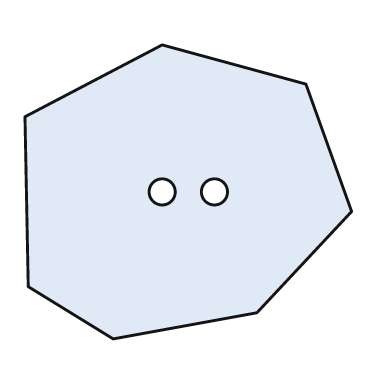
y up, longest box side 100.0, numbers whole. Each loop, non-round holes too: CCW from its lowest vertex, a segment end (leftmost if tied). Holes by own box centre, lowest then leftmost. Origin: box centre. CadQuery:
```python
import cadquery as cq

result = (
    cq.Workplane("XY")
    .moveTo(-23.0, -45.0)
    .lineTo(21.0, -37.0)
    .lineTo(50.0, -6.0)
    .lineTo(36.0, 33.0)
    .lineTo(-8.0, 45.0)
    .lineTo(-50.0, 23.0)
    .lineTo(-49.0, -29.0)
    .close()
    .moveTo(-8.0, 0.0)
    .circle(4.0)
    .moveTo(8.0, 0.0)
    .circle(4.0)
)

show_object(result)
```